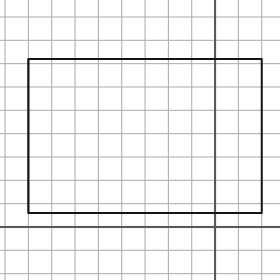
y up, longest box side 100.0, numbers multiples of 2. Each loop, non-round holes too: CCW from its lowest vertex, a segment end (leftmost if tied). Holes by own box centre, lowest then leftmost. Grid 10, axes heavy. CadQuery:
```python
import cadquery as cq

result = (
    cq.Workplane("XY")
    .moveTo(-80.0, 6.0)
    .lineTo(20.0, 6.0)
    .lineTo(20.0, 72.0)
    .lineTo(-80.0, 72.0)
    .close()
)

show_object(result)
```